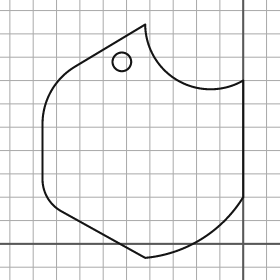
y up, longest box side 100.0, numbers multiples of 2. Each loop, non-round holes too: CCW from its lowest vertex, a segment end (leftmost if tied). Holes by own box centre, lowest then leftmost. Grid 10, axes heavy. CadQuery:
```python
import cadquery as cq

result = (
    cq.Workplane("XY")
    .moveTo(-42.0, -6.0)
    .threePointArc((-18.0, 2.0), (0.0, 20.0))
    .lineTo(0.0, 70.0)
    .threePointArc((-28.0, 70.0), (-42.0, 94.0))
    .lineTo(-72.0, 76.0)
    .threePointArc((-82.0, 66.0), (-86.0, 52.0))
    .lineTo(-86.0, 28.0)
    .threePointArc((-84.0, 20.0), (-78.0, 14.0))
    .close()
    .moveTo(-52.0, 78.0)
    .circle(4.0)
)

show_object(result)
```